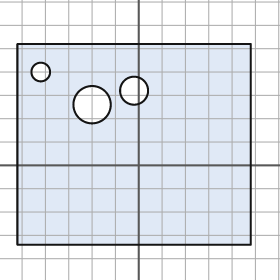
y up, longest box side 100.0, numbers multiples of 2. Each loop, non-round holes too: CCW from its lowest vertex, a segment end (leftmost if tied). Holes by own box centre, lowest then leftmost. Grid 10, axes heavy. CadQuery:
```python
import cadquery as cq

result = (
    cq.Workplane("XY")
    .moveTo(-52.0, -34.0)
    .lineTo(48.0, -34.0)
    .lineTo(48.0, 52.0)
    .lineTo(-52.0, 52.0)
    .close()
    .moveTo(-20.0, 26.0)
    .circle(8.0)
    .moveTo(-2.0, 32.0)
    .circle(6.0)
    .moveTo(-42.0, 40.0)
    .circle(4.0)
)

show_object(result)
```